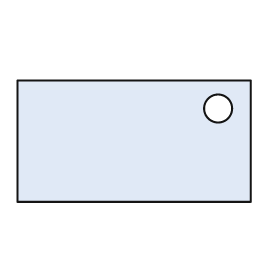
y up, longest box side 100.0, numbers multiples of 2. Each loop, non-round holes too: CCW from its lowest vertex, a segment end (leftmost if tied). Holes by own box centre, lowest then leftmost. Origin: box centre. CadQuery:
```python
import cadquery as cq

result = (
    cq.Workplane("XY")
    .moveTo(-50.0, -26.0)
    .lineTo(50.0, -26.0)
    .lineTo(50.0, 26.0)
    .lineTo(-50.0, 26.0)
    .close()
    .moveTo(36.0, 14.0)
    .circle(6.0)
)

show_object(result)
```